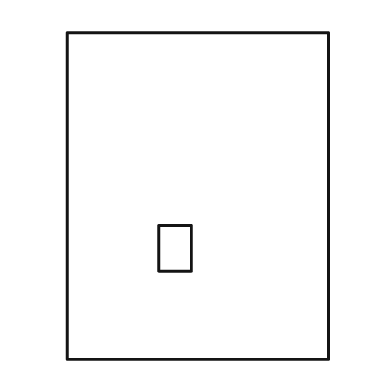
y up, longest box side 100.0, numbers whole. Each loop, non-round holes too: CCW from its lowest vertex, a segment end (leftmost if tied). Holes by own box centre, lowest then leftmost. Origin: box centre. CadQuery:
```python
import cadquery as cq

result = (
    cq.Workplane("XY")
    .moveTo(-40.0, -50.0)
    .lineTo(40.0, -50.0)
    .lineTo(40.0, 50.0)
    .lineTo(-40.0, 50.0)
    .close()
    .moveTo(-12.0, -23.0)
    .lineTo(-2.0, -23.0)
    .lineTo(-2.0, -9.0)
    .lineTo(-12.0, -9.0)
    .close()
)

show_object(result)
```